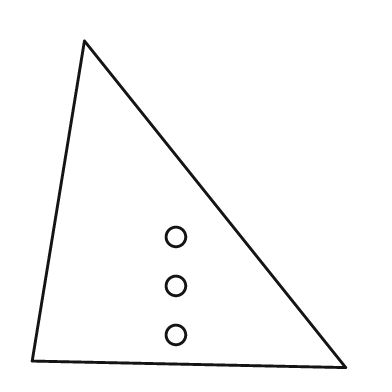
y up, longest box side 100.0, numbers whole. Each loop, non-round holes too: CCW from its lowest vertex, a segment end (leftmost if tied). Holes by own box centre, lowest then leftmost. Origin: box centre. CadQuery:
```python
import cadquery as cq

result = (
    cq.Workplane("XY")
    .moveTo(48.0, -50.0)
    .lineTo(-32.0, 50.0)
    .lineTo(-48.0, -48.0)
    .close()
    .moveTo(-4.0, -40.0)
    .circle(3.0)
    .moveTo(-4.0, -25.0)
    .circle(3.0)
    .moveTo(-4.0, -10.0)
    .circle(3.0)
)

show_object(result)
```